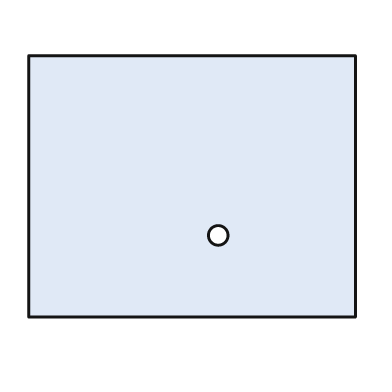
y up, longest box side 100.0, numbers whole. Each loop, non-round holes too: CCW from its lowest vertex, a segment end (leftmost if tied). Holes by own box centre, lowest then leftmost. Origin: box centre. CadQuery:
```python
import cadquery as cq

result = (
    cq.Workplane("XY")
    .moveTo(-50.0, -40.0)
    .lineTo(50.0, -40.0)
    .lineTo(50.0, 40.0)
    .lineTo(-50.0, 40.0)
    .close()
    .moveTo(8.0, -15.0)
    .circle(3.0)
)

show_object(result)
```